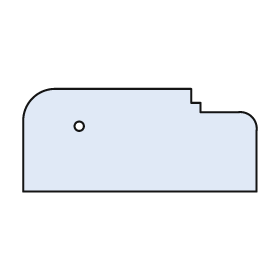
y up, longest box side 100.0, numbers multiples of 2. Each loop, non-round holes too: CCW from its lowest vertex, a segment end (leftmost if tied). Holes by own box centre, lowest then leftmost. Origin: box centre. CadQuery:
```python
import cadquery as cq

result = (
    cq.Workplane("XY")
    .moveTo(-50.0, -22.0)
    .lineTo(50.0, -22.0)
    .lineTo(50.0, 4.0)
    .threePointArc((48.0, 10.0), (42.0, 12.0))
    .lineTo(26.0, 12.0)
    .lineTo(26.0, 16.0)
    .lineTo(22.0, 16.0)
    .lineTo(22.0, 22.0)
    .lineTo(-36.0, 22.0)
    .threePointArc((-46.0, 18.0), (-50.0, 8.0))
    .close()
    .moveTo(-26.0, 6.0)
    .circle(2.0)
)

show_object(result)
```